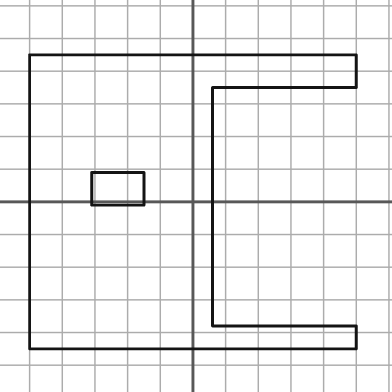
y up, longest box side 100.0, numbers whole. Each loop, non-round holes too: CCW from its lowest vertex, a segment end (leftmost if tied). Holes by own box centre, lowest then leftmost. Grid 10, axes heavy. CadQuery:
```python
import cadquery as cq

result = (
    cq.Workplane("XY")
    .moveTo(-50.0, -45.0)
    .lineTo(50.0, -45.0)
    .lineTo(50.0, -38.0)
    .lineTo(6.0, -38.0)
    .lineTo(6.0, 35.0)
    .lineTo(50.0, 35.0)
    .lineTo(50.0, 45.0)
    .lineTo(-50.0, 45.0)
    .close()
    .moveTo(-31.0, -1.0)
    .lineTo(-15.0, -1.0)
    .lineTo(-15.0, 9.0)
    .lineTo(-31.0, 9.0)
    .close()
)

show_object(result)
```